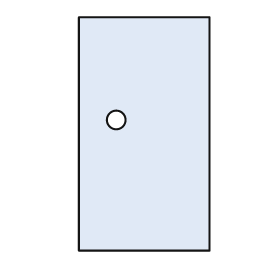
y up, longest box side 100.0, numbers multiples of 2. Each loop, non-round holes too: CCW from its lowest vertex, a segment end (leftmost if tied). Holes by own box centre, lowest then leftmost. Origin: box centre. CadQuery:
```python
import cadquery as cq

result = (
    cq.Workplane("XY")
    .moveTo(-28.0, -50.0)
    .lineTo(28.0, -50.0)
    .lineTo(28.0, 50.0)
    .lineTo(-28.0, 50.0)
    .close()
    .moveTo(-12.0, 6.0)
    .circle(4.0)
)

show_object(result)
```